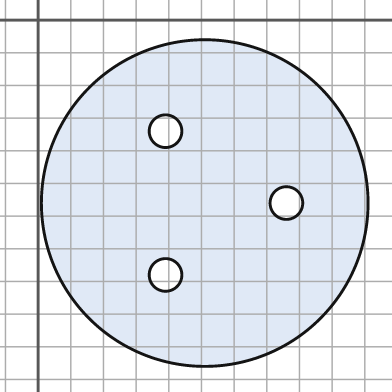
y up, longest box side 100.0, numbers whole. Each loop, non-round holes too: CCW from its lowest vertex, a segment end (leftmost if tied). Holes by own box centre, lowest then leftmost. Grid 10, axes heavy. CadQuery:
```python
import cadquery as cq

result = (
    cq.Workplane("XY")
    .moveTo(51.0, -56.0)
    .circle(50.0)
    .moveTo(39.0, -78.0)
    .circle(5.0)
    .moveTo(76.0, -56.0)
    .circle(5.0)
    .moveTo(39.0, -34.0)
    .circle(5.0)
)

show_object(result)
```